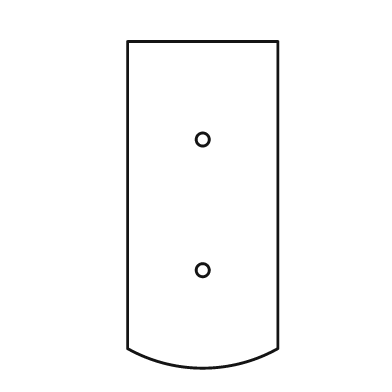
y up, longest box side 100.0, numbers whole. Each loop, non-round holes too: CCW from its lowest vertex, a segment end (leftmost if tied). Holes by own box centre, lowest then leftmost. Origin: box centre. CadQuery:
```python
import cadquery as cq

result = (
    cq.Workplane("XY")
    .moveTo(-23.0, -44.0)
    .threePointArc((0.0, -50.0), (23.0, -44.0))
    .lineTo(23.0, 50.0)
    .lineTo(-23.0, 50.0)
    .close()
    .moveTo(0.0, -20.0)
    .circle(2.0)
    .moveTo(0.0, 20.0)
    .circle(2.0)
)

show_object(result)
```